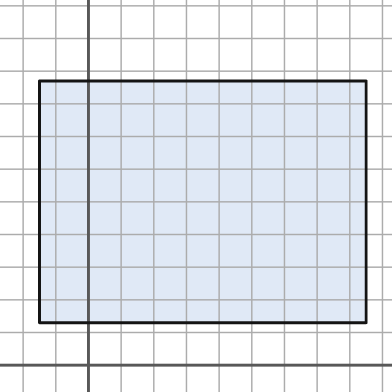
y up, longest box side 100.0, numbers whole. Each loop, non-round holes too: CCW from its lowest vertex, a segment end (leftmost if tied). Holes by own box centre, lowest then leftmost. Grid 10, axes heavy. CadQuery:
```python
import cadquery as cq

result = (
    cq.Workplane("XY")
    .moveTo(-15.0, 13.0)
    .lineTo(85.0, 13.0)
    .lineTo(85.0, 87.0)
    .lineTo(-15.0, 87.0)
    .close()
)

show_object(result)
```